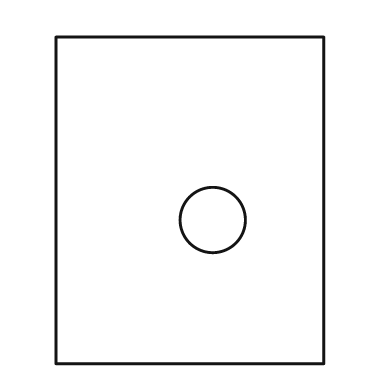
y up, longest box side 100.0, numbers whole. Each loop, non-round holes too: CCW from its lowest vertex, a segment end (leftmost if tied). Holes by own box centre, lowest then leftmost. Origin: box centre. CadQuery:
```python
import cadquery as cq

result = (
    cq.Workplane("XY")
    .moveTo(-41.0, -50.0)
    .lineTo(41.0, -50.0)
    .lineTo(41.0, 50.0)
    .lineTo(-41.0, 50.0)
    .close()
    .moveTo(7.0, -6.0)
    .circle(10.0)
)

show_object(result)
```